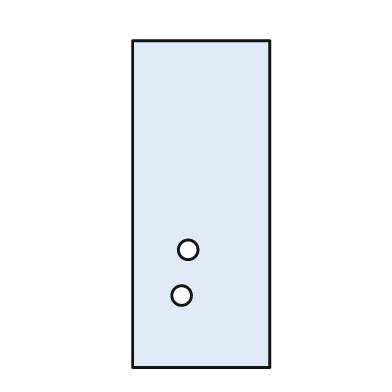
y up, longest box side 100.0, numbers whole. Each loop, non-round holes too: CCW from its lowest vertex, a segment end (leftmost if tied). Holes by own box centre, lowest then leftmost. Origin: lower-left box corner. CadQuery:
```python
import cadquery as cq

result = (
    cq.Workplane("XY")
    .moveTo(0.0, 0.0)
    .lineTo(42.0, 0.0)
    .lineTo(42.0, 100.0)
    .lineTo(0.0, 100.0)
    .close()
    .moveTo(15.0, 22.0)
    .circle(3.0)
    .moveTo(17.0, 36.0)
    .circle(3.0)
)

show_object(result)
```